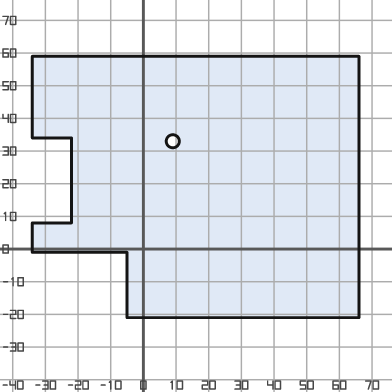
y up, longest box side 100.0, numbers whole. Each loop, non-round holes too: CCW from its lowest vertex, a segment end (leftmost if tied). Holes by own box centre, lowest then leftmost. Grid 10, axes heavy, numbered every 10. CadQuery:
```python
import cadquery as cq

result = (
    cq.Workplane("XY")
    .moveTo(-5.0, -21.0)
    .lineTo(66.0, -21.0)
    .lineTo(66.0, 59.0)
    .lineTo(-34.0, 59.0)
    .lineTo(-34.0, 34.0)
    .lineTo(-22.0, 34.0)
    .lineTo(-22.0, 8.0)
    .lineTo(-34.0, 8.0)
    .lineTo(-34.0, -1.0)
    .lineTo(-5.0, -1.0)
    .close()
    .moveTo(9.0, 33.0)
    .circle(2.0)
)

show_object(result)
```